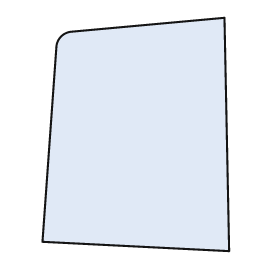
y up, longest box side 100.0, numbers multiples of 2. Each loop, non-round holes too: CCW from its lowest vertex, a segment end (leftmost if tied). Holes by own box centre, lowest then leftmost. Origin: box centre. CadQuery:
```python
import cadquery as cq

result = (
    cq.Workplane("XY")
    .moveTo(40.0, -50.0)
    .lineTo(38.0, 50.0)
    .lineTo(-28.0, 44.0)
    .threePointArc((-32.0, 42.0), (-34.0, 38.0))
    .lineTo(-40.0, -46.0)
    .close()
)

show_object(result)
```